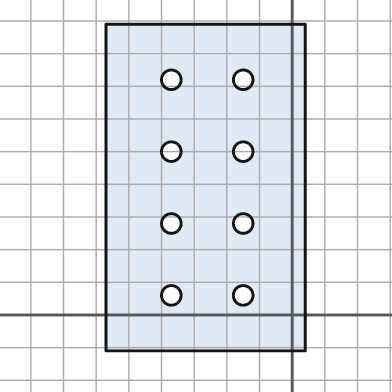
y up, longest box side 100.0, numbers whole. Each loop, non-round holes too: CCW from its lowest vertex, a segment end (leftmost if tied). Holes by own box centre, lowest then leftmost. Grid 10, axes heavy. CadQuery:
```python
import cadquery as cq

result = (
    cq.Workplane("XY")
    .moveTo(-57.0, -11.0)
    .lineTo(4.0, -11.0)
    .lineTo(4.0, 89.0)
    .lineTo(-57.0, 89.0)
    .close()
    .moveTo(-37.0, 6.0)
    .circle(3.0)
    .moveTo(-15.0, 6.0)
    .circle(3.0)
    .moveTo(-37.0, 28.0)
    .circle(3.0)
    .moveTo(-15.0, 28.0)
    .circle(3.0)
    .moveTo(-37.0, 50.0)
    .circle(3.0)
    .moveTo(-15.0, 50.0)
    .circle(3.0)
    .moveTo(-37.0, 72.0)
    .circle(3.0)
    .moveTo(-15.0, 72.0)
    .circle(3.0)
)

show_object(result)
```